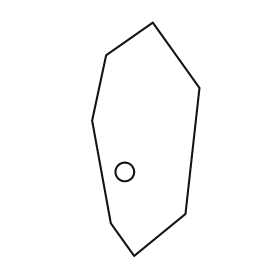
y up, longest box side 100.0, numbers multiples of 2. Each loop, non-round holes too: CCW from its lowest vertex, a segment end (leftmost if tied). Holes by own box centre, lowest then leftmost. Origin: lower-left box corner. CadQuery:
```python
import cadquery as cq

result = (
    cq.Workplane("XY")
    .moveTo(18.0, 0.0)
    .lineTo(40.0, 18.0)
    .lineTo(46.0, 72.0)
    .lineTo(26.0, 100.0)
    .lineTo(6.0, 86.0)
    .lineTo(0.0, 58.0)
    .lineTo(8.0, 14.0)
    .close()
    .moveTo(14.0, 36.0)
    .circle(4.0)
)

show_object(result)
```